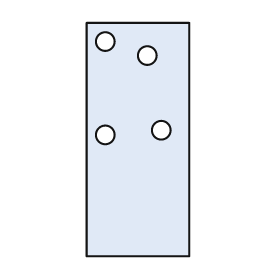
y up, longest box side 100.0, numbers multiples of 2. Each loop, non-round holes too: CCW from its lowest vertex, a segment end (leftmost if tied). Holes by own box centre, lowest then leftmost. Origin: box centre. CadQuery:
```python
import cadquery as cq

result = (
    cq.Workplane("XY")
    .moveTo(-22.0, -50.0)
    .lineTo(22.0, -50.0)
    .lineTo(22.0, 50.0)
    .lineTo(-22.0, 50.0)
    .close()
    .moveTo(-14.0, 2.0)
    .circle(4.0)
    .moveTo(10.0, 4.0)
    .circle(4.0)
    .moveTo(4.0, 36.0)
    .circle(4.0)
    .moveTo(-14.0, 42.0)
    .circle(4.0)
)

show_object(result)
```